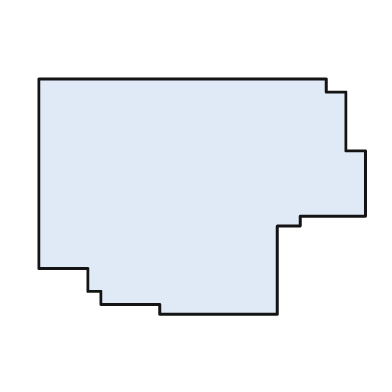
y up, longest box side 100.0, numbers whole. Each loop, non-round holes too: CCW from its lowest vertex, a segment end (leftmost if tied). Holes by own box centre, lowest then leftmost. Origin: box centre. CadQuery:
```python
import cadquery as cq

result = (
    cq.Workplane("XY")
    .moveTo(-13.0, -36.0)
    .lineTo(23.0, -36.0)
    .lineTo(23.0, -9.0)
    .lineTo(30.0, -9.0)
    .lineTo(30.0, -6.0)
    .lineTo(50.0, -6.0)
    .lineTo(50.0, 14.0)
    .lineTo(44.0, 14.0)
    .lineTo(44.0, 32.0)
    .lineTo(38.0, 32.0)
    .lineTo(38.0, 36.0)
    .lineTo(-50.0, 36.0)
    .lineTo(-50.0, -22.0)
    .lineTo(-35.0, -22.0)
    .lineTo(-35.0, -29.0)
    .lineTo(-31.0, -29.0)
    .lineTo(-31.0, -33.0)
    .lineTo(-13.0, -33.0)
    .close()
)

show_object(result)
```